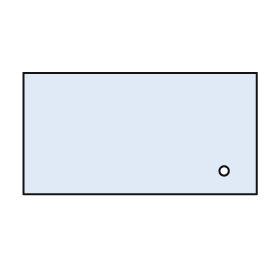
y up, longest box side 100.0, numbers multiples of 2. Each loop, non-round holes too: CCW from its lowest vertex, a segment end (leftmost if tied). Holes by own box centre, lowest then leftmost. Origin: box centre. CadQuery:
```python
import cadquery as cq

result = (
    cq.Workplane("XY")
    .moveTo(-50.0, -26.0)
    .lineTo(50.0, -26.0)
    .lineTo(50.0, 26.0)
    .lineTo(-50.0, 26.0)
    .close()
    .moveTo(36.0, -16.0)
    .circle(2.0)
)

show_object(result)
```